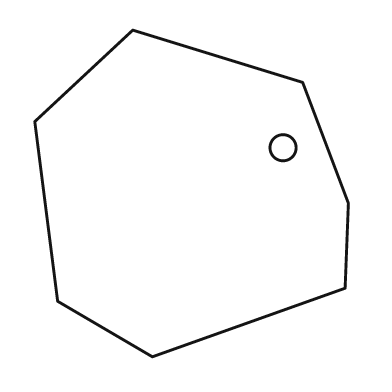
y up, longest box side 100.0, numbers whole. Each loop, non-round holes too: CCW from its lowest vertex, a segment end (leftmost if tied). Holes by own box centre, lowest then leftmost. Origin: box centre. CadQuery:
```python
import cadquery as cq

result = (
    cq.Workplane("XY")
    .moveTo(-12.0, -50.0)
    .lineTo(47.0, -29.0)
    .lineTo(48.0, -3.0)
    .lineTo(34.0, 34.0)
    .lineTo(-18.0, 50.0)
    .lineTo(-48.0, 22.0)
    .lineTo(-41.0, -33.0)
    .close()
    .moveTo(28.0, 14.0)
    .circle(4.0)
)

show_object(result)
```